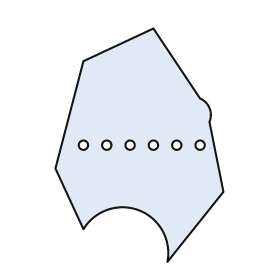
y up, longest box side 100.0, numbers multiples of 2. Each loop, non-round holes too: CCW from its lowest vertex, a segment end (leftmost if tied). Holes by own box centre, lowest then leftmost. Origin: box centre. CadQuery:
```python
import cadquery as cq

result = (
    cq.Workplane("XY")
    .moveTo(12.0, -50.0)
    .lineTo(36.0, -20.0)
    .lineTo(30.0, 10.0)
    .threePointArc((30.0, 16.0), (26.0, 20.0))
    .lineTo(6.0, 50.0)
    .lineTo(-24.0, 36.0)
    .lineTo(-36.0, -10.0)
    .lineTo(-24.0, -36.0)
    .threePointArc((0.0, -28.0), (12.0, -50.0))
    .close()
    .moveTo(-24.0, 0.0)
    .circle(2.0)
    .moveTo(-14.0, 0.0)
    .circle(2.0)
    .moveTo(-4.0, 0.0)
    .circle(2.0)
    .moveTo(6.0, 0.0)
    .circle(2.0)
    .moveTo(16.0, 0.0)
    .circle(2.0)
    .moveTo(26.0, 0.0)
    .circle(2.0)
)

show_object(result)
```